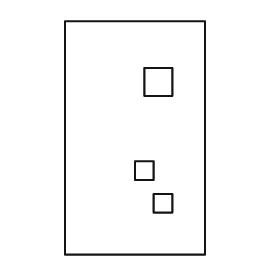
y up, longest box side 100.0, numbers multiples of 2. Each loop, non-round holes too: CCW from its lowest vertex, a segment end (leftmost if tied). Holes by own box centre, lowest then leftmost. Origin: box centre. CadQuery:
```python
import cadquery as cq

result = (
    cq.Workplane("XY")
    .moveTo(-30.0, -50.0)
    .lineTo(30.0, -50.0)
    .lineTo(30.0, 50.0)
    .lineTo(-30.0, 50.0)
    .close()
    .moveTo(8.0, -32.0)
    .lineTo(16.0, -32.0)
    .lineTo(16.0, -24.0)
    .lineTo(8.0, -24.0)
    .close()
    .moveTo(0.0, -18.0)
    .lineTo(8.0, -18.0)
    .lineTo(8.0, -10.0)
    .lineTo(0.0, -10.0)
    .close()
    .moveTo(4.0, 18.0)
    .lineTo(16.0, 18.0)
    .lineTo(16.0, 30.0)
    .lineTo(4.0, 30.0)
    .close()
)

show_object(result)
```